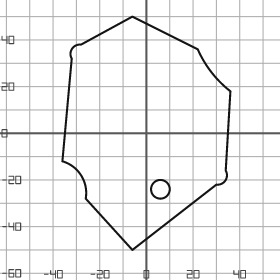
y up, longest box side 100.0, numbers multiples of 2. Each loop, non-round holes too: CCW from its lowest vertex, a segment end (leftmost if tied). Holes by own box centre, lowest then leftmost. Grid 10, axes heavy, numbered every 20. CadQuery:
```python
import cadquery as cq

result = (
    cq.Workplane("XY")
    .moveTo(-6.0, -50.0)
    .lineTo(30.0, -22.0)
    .threePointArc((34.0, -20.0), (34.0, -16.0))
    .lineTo(36.0, 18.0)
    .threePointArc((28.0, 26.0), (22.0, 36.0))
    .lineTo(-6.0, 50.0)
    .lineTo(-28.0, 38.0)
    .threePointArc((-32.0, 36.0), (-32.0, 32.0))
    .lineTo(-36.0, -12.0)
    .threePointArc((-28.0, -18.0), (-26.0, -28.0))
    .close()
    .moveTo(6.0, -24.0)
    .circle(4.0)
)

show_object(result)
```